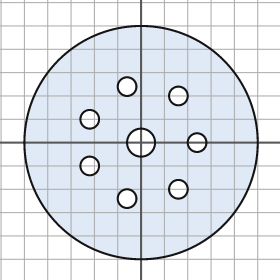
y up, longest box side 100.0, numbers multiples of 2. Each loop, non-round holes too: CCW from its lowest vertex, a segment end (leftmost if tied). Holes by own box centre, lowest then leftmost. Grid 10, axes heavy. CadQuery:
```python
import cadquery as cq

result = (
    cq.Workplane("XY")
    .moveTo(0.0, 0.0)
    .circle(50.0)
    .moveTo(-6.0, -24.0)
    .circle(4.0)
    .moveTo(16.0, -20.0)
    .circle(4.0)
    .moveTo(-22.0, -10.0)
    .circle(4.0)
    .moveTo(0.0, 0.0)
    .circle(6.0)
    .moveTo(24.0, 0.0)
    .circle(4.0)
    .moveTo(-22.0, 10.0)
    .circle(4.0)
    .moveTo(16.0, 20.0)
    .circle(4.0)
    .moveTo(-6.0, 24.0)
    .circle(4.0)
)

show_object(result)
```